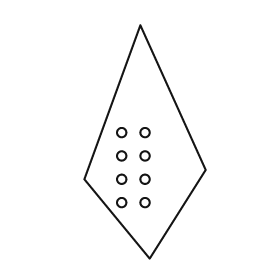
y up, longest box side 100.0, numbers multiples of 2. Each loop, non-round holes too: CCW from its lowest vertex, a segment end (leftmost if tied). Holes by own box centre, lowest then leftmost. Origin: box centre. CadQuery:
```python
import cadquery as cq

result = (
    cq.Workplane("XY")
    .moveTo(2.0, -50.0)
    .lineTo(26.0, -12.0)
    .lineTo(-2.0, 50.0)
    .lineTo(-26.0, -16.0)
    .close()
    .moveTo(-10.0, -26.0)
    .circle(2.0)
    .moveTo(0.0, -26.0)
    .circle(2.0)
    .moveTo(-10.0, -16.0)
    .circle(2.0)
    .moveTo(0.0, -16.0)
    .circle(2.0)
    .moveTo(-10.0, -6.0)
    .circle(2.0)
    .moveTo(0.0, -6.0)
    .circle(2.0)
    .moveTo(-10.0, 4.0)
    .circle(2.0)
    .moveTo(0.0, 4.0)
    .circle(2.0)
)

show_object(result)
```